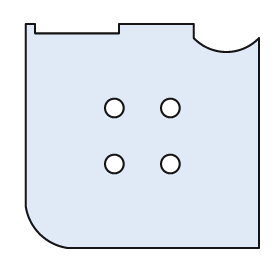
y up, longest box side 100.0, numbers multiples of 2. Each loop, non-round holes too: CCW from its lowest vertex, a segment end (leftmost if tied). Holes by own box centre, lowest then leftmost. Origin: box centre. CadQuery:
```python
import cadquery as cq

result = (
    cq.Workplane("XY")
    .moveTo(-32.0, -48.0)
    .lineTo(50.0, -48.0)
    .lineTo(50.0, 42.0)
    .threePointArc((36.0, 36.0), (22.0, 42.0))
    .lineTo(22.0, 48.0)
    .lineTo(-10.0, 48.0)
    .lineTo(-10.0, 44.0)
    .lineTo(-46.0, 44.0)
    .lineTo(-46.0, 48.0)
    .lineTo(-50.0, 48.0)
    .lineTo(-50.0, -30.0)
    .threePointArc((-44.0, -42.0), (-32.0, -48.0))
    .close()
    .moveTo(-12.0, -12.0)
    .circle(4.0)
    .moveTo(12.0, -12.0)
    .circle(4.0)
    .moveTo(-12.0, 12.0)
    .circle(4.0)
    .moveTo(12.0, 12.0)
    .circle(4.0)
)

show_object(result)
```